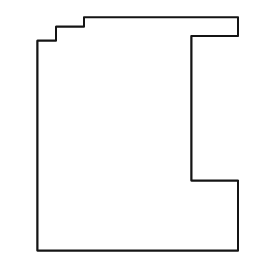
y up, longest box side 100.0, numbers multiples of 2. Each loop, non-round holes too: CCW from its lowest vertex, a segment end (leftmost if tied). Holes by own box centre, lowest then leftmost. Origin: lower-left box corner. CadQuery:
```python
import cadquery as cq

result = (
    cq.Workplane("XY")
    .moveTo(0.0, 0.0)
    .lineTo(86.0, 0.0)
    .lineTo(86.0, 30.0)
    .lineTo(66.0, 30.0)
    .lineTo(66.0, 92.0)
    .lineTo(86.0, 92.0)
    .lineTo(86.0, 100.0)
    .lineTo(20.0, 100.0)
    .lineTo(20.0, 96.0)
    .lineTo(8.0, 96.0)
    .lineTo(8.0, 90.0)
    .lineTo(0.0, 90.0)
    .close()
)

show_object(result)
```